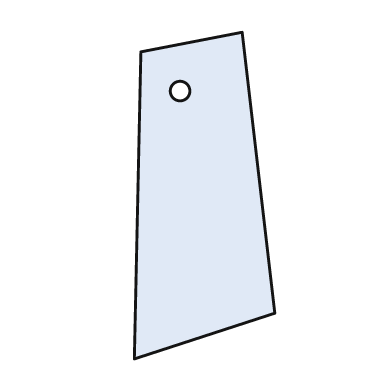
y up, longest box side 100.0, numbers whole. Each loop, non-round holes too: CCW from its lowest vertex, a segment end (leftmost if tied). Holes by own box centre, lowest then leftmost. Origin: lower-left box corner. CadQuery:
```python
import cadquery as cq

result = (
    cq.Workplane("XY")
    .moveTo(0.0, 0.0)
    .lineTo(43.0, 14.0)
    .lineTo(33.0, 100.0)
    .lineTo(2.0, 94.0)
    .close()
    .moveTo(14.0, 82.0)
    .circle(3.0)
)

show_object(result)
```